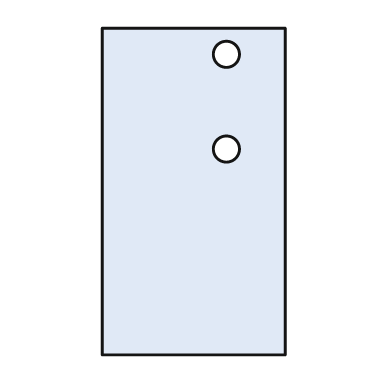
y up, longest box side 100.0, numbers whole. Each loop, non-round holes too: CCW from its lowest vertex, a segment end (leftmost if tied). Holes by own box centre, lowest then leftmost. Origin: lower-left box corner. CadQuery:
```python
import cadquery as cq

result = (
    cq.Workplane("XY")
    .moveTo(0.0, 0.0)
    .lineTo(56.0, 0.0)
    .lineTo(56.0, 100.0)
    .lineTo(0.0, 100.0)
    .close()
    .moveTo(38.0, 63.0)
    .circle(4.0)
    .moveTo(38.0, 92.0)
    .circle(4.0)
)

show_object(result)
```